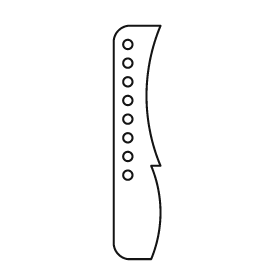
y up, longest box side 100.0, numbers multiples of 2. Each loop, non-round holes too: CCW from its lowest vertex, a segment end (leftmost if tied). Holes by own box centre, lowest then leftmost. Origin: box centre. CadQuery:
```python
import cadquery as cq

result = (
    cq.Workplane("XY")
    .moveTo(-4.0, -50.0)
    .lineTo(6.0, -50.0)
    .threePointArc((10.0, -30.0), (6.0, -10.0))
    .lineTo(10.0, -10.0)
    .threePointArc((4.0, 20.0), (10.0, 50.0))
    .lineTo(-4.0, 50.0)
    .threePointArc((-8.0, 48.0), (-10.0, 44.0))
    .lineTo(-10.0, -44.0)
    .threePointArc((-8.0, -48.0), (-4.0, -50.0))
    .close()
    .moveTo(-4.0, -14.0)
    .circle(2.0)
    .moveTo(-4.0, -6.0)
    .circle(2.0)
    .moveTo(-4.0, 2.0)
    .circle(2.0)
    .moveTo(-4.0, 10.0)
    .circle(2.0)
    .moveTo(-4.0, 18.0)
    .circle(2.0)
    .moveTo(-4.0, 26.0)
    .circle(2.0)
    .moveTo(-4.0, 34.0)
    .circle(2.0)
    .moveTo(-4.0, 42.0)
    .circle(2.0)
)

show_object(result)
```